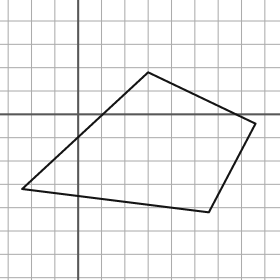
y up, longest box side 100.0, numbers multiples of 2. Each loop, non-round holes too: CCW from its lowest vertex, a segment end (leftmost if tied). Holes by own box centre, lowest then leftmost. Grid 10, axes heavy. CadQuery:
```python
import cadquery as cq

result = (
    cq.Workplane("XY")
    .moveTo(56.0, -42.0)
    .lineTo(76.0, -4.0)
    .lineTo(30.0, 18.0)
    .lineTo(-24.0, -32.0)
    .close()
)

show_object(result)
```